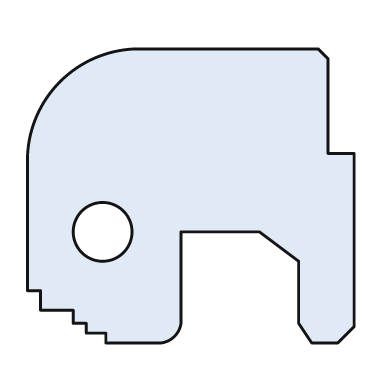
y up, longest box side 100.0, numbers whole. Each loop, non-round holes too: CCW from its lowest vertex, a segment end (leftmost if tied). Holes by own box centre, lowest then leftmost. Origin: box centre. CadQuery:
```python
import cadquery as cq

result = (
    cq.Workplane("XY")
    .moveTo(-26.0, -45.0)
    .lineTo(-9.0, -45.0)
    .threePointArc((-5.0, -43.0), (-3.0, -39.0))
    .lineTo(-3.0, -11.0)
    .lineTo(21.0, -11.0)
    .lineTo(33.0, -20.0)
    .lineTo(33.0, -39.0)
    .lineTo(37.0, -45.0)
    .lineTo(45.0, -45.0)
    .lineTo(50.0, -40.0)
    .lineTo(50.0, 13.0)
    .lineTo(42.0, 13.0)
    .lineTo(42.0, 42.0)
    .lineTo(39.0, 45.0)
    .lineTo(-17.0, 45.0)
    .threePointArc((-40.0, 35.0), (-50.0, 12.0))
    .lineTo(-50.0, -29.0)
    .lineTo(-46.0, -29.0)
    .lineTo(-46.0, -35.0)
    .lineTo(-36.0, -35.0)
    .lineTo(-36.0, -39.0)
    .lineTo(-32.0, -39.0)
    .lineTo(-32.0, -42.0)
    .lineTo(-26.0, -42.0)
    .close()
    .moveTo(-27.0, -11.0)
    .circle(9.0)
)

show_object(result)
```